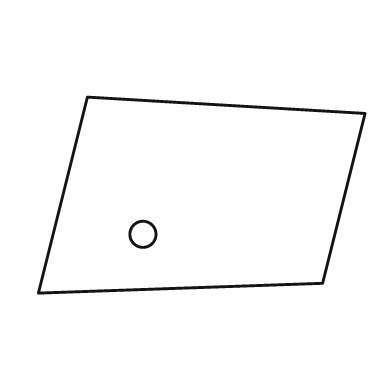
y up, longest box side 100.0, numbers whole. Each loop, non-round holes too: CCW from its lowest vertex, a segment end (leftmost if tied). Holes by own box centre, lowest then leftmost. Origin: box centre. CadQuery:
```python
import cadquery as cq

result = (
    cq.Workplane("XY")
    .moveTo(-50.0, -30.0)
    .lineTo(37.0, -27.0)
    .lineTo(50.0, 25.0)
    .lineTo(-35.0, 30.0)
    .close()
    .moveTo(-18.0, -12.0)
    .circle(4.0)
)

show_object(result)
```